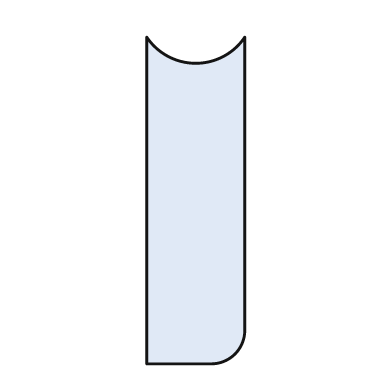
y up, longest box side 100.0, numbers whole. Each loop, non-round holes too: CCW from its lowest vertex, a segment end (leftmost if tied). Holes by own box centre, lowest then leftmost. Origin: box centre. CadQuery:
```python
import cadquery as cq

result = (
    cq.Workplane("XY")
    .moveTo(-15.0, -50.0)
    .lineTo(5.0, -50.0)
    .threePointArc((12.0, -47.0), (15.0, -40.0))
    .lineTo(15.0, 50.0)
    .threePointArc((0.0, 42.0), (-15.0, 50.0))
    .close()
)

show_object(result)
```